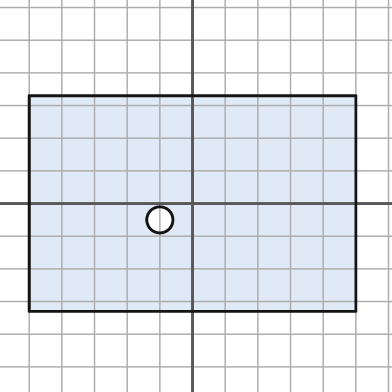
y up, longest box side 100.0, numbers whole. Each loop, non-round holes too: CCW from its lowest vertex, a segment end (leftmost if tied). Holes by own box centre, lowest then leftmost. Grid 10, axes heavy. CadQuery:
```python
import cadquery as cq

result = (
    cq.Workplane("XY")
    .moveTo(-50.0, -33.0)
    .lineTo(50.0, -33.0)
    .lineTo(50.0, 33.0)
    .lineTo(-50.0, 33.0)
    .close()
    .moveTo(-10.0, -5.0)
    .circle(4.0)
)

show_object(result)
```